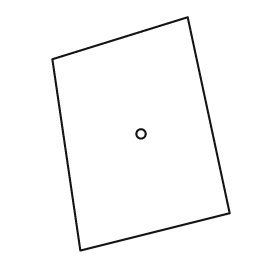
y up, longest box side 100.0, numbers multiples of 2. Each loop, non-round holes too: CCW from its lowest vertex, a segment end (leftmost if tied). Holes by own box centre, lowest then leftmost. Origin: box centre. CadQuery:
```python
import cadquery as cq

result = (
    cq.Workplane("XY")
    .moveTo(-26.0, -50.0)
    .lineTo(38.0, -34.0)
    .lineTo(20.0, 50.0)
    .lineTo(-38.0, 32.0)
    .close()
    .moveTo(0.0, 0.0)
    .circle(2.0)
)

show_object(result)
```